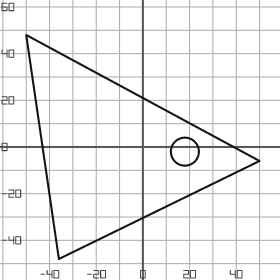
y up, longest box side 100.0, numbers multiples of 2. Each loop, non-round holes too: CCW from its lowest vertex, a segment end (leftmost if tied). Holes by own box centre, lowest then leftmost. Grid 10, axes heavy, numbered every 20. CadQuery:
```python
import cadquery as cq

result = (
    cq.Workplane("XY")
    .moveTo(-36.0, -48.0)
    .lineTo(50.0, -6.0)
    .lineTo(-50.0, 48.0)
    .close()
    .moveTo(18.0, -2.0)
    .circle(6.0)
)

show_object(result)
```